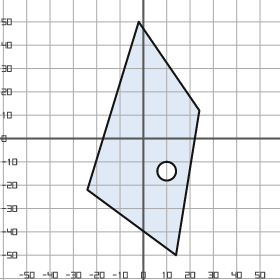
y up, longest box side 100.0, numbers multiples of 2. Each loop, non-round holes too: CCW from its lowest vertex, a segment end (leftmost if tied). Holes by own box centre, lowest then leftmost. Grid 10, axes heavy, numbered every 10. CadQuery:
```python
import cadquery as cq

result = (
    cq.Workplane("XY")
    .moveTo(14.0, -50.0)
    .lineTo(24.0, 12.0)
    .lineTo(-2.0, 50.0)
    .lineTo(-24.0, -22.0)
    .close()
    .moveTo(10.0, -14.0)
    .circle(4.0)
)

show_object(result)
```